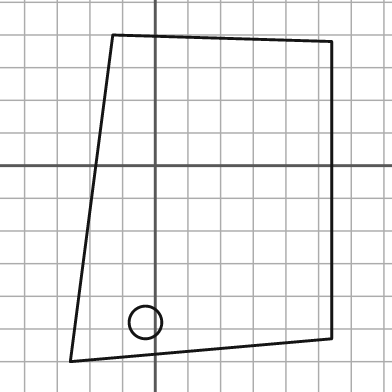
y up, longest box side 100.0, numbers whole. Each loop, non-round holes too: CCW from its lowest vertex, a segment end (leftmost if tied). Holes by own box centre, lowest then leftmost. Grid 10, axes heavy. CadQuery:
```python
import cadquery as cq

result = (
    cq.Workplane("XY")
    .moveTo(-26.0, -60.0)
    .lineTo(54.0, -53.0)
    .lineTo(54.0, 38.0)
    .lineTo(-13.0, 40.0)
    .close()
    .moveTo(-3.0, -48.0)
    .circle(5.0)
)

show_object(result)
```